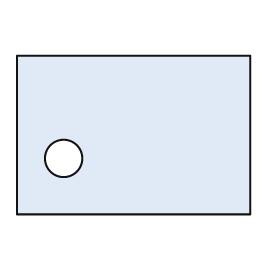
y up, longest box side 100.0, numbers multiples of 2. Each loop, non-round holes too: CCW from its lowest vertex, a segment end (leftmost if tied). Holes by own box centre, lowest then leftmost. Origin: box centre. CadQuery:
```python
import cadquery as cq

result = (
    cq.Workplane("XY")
    .moveTo(-50.0, -34.0)
    .lineTo(50.0, -34.0)
    .lineTo(50.0, 34.0)
    .lineTo(-50.0, 34.0)
    .close()
    .moveTo(-30.0, -10.0)
    .circle(8.0)
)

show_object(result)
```